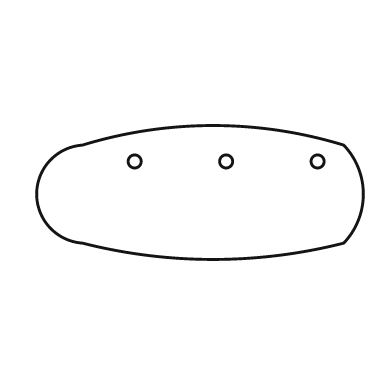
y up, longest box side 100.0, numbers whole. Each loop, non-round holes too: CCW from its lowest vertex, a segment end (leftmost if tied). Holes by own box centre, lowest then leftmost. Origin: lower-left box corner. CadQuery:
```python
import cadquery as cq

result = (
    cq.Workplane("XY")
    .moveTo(14.0, 5.0)
    .threePointArc((54.0, 0.0), (94.0, 5.0))
    .threePointArc((100.0, 20.0), (94.0, 35.0))
    .threePointArc((54.0, 41.0), (14.0, 35.0))
    .threePointArc((0.0, 20.0), (14.0, 5.0))
    .close()
    .moveTo(30.0, 30.0)
    .circle(2.0)
    .moveTo(58.0, 30.0)
    .circle(2.0)
    .moveTo(86.0, 30.0)
    .circle(2.0)
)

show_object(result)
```